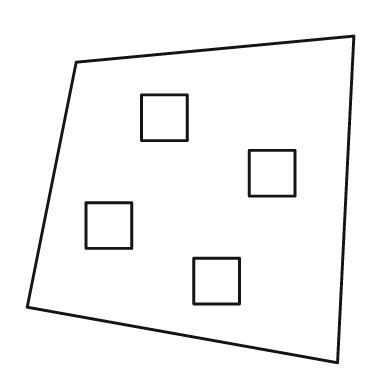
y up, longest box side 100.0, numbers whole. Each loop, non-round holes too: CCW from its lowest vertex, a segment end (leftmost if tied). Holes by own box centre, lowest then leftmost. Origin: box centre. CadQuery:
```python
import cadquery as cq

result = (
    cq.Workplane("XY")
    .moveTo(45.0, -50.0)
    .lineTo(50.0, 50.0)
    .lineTo(-35.0, 42.0)
    .lineTo(-50.0, -33.0)
    .close()
    .moveTo(1.0, -32.0)
    .lineTo(15.0, -32.0)
    .lineTo(15.0, -18.0)
    .lineTo(1.0, -18.0)
    .close()
    .moveTo(-32.0, -15.0)
    .lineTo(-18.0, -15.0)
    .lineTo(-18.0, -1.0)
    .lineTo(-32.0, -1.0)
    .close()
    .moveTo(18.0, 1.0)
    .lineTo(32.0, 1.0)
    .lineTo(32.0, 15.0)
    .lineTo(18.0, 15.0)
    .close()
    .moveTo(-15.0, 18.0)
    .lineTo(-1.0, 18.0)
    .lineTo(-1.0, 32.0)
    .lineTo(-15.0, 32.0)
    .close()
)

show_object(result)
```